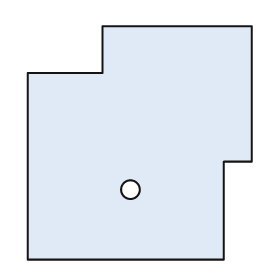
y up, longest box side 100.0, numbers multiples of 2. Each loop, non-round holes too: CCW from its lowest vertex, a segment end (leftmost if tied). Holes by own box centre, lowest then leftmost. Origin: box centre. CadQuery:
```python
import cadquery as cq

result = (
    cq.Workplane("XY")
    .moveTo(-48.0, -50.0)
    .lineTo(36.0, -50.0)
    .lineTo(36.0, -8.0)
    .lineTo(48.0, -8.0)
    .lineTo(48.0, 50.0)
    .lineTo(-16.0, 50.0)
    .lineTo(-16.0, 30.0)
    .lineTo(-48.0, 30.0)
    .close()
    .moveTo(-4.0, -20.0)
    .circle(4.0)
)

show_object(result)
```